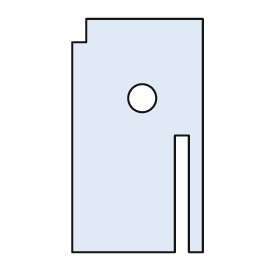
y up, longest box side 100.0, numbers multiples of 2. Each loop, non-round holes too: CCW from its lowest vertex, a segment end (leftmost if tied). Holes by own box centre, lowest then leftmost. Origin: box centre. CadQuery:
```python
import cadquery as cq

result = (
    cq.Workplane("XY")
    .moveTo(-28.0, -50.0)
    .lineTo(16.0, -50.0)
    .lineTo(16.0, 0.0)
    .lineTo(22.0, 0.0)
    .lineTo(22.0, -50.0)
    .lineTo(28.0, -50.0)
    .lineTo(28.0, 50.0)
    .lineTo(-22.0, 50.0)
    .lineTo(-22.0, 40.0)
    .lineTo(-28.0, 40.0)
    .close()
    .moveTo(2.0, 16.0)
    .circle(6.0)
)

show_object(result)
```